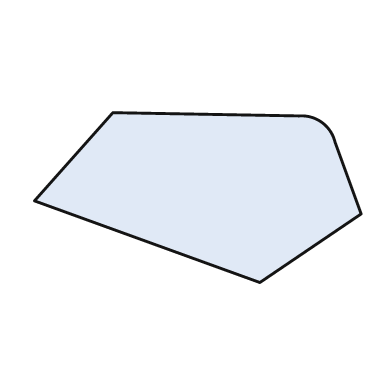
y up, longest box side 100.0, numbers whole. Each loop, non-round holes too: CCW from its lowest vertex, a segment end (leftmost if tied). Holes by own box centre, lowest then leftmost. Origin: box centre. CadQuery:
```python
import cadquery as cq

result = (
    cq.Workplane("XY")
    .moveTo(19.0, -26.0)
    .lineTo(50.0, -5.0)
    .lineTo(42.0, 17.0)
    .threePointArc((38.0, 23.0), (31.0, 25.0))
    .lineTo(-26.0, 26.0)
    .lineTo(-50.0, -1.0)
    .close()
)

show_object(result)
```